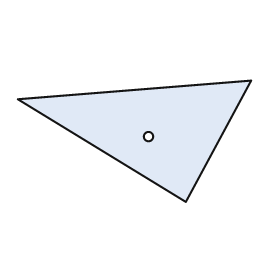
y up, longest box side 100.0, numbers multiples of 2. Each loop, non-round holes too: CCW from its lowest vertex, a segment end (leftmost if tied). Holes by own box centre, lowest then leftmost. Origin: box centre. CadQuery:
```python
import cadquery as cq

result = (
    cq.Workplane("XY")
    .moveTo(22.0, -26.0)
    .lineTo(50.0, 26.0)
    .lineTo(-50.0, 18.0)
    .close()
    .moveTo(6.0, 2.0)
    .circle(2.0)
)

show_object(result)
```